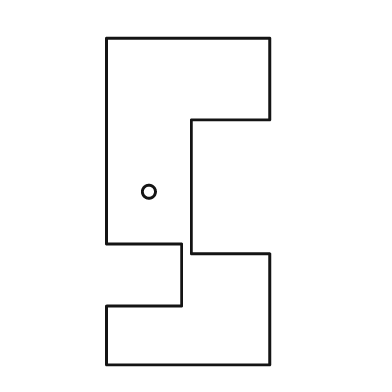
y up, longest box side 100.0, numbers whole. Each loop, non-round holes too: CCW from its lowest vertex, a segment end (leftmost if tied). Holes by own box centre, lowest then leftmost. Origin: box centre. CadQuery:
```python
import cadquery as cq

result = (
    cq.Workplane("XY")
    .moveTo(-25.0, -50.0)
    .lineTo(25.0, -50.0)
    .lineTo(25.0, -16.0)
    .lineTo(1.0, -16.0)
    .lineTo(1.0, 25.0)
    .lineTo(25.0, 25.0)
    .lineTo(25.0, 50.0)
    .lineTo(-25.0, 50.0)
    .lineTo(-25.0, -13.0)
    .lineTo(-2.0, -13.0)
    .lineTo(-2.0, -32.0)
    .lineTo(-25.0, -32.0)
    .close()
    .moveTo(-12.0, 3.0)
    .circle(2.0)
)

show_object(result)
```